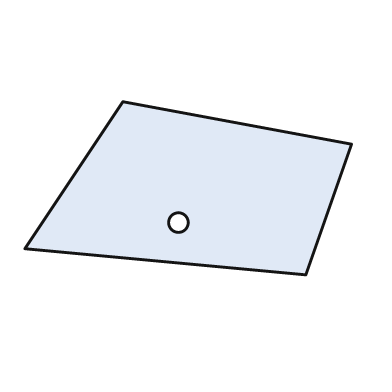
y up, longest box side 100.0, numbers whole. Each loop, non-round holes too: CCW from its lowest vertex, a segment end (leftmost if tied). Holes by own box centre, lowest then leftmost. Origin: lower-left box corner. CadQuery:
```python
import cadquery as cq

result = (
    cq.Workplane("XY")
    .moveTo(86.0, 0.0)
    .lineTo(100.0, 40.0)
    .lineTo(30.0, 53.0)
    .lineTo(0.0, 8.0)
    .close()
    .moveTo(47.0, 16.0)
    .circle(3.0)
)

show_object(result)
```